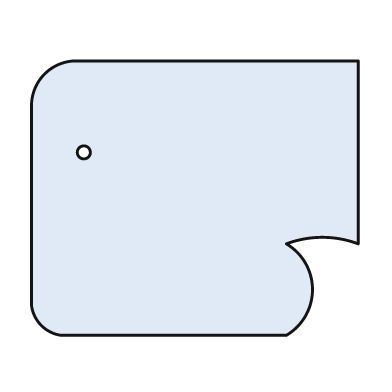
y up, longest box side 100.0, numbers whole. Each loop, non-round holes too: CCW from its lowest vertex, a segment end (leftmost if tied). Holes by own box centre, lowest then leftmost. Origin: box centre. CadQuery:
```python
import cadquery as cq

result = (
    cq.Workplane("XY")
    .moveTo(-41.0, -42.0)
    .lineTo(28.0, -42.0)
    .threePointArc((36.0, -28.0), (28.0, -14.0))
    .threePointArc((39.0, -12.0), (50.0, -14.0))
    .lineTo(50.0, 42.0)
    .lineTo(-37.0, 42.0)
    .threePointArc((-46.0, 38.0), (-50.0, 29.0))
    .lineTo(-50.0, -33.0)
    .threePointArc((-47.0, -39.0), (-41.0, -42.0))
    .close()
    .moveTo(-34.0, 14.0)
    .circle(2.0)
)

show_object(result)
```